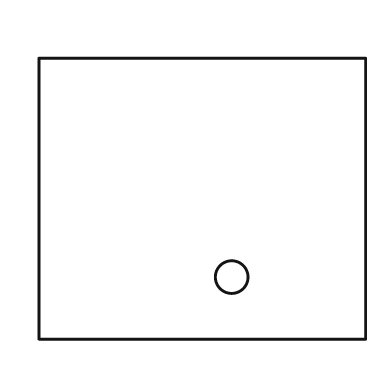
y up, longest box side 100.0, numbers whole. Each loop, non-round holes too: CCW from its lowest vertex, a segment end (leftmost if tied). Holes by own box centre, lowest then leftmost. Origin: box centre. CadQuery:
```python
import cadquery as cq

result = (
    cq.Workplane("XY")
    .moveTo(-50.0, -43.0)
    .lineTo(50.0, -43.0)
    .lineTo(50.0, 43.0)
    .lineTo(-50.0, 43.0)
    .close()
    .moveTo(9.0, -24.0)
    .circle(5.0)
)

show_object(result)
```